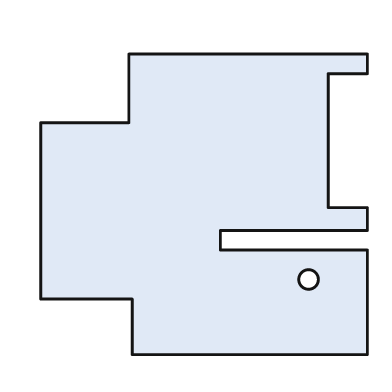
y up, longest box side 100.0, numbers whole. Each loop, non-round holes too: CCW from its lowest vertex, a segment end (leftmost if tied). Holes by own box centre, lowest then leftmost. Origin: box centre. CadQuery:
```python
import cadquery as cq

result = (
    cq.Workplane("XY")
    .moveTo(-22.0, -46.0)
    .lineTo(50.0, -46.0)
    .lineTo(50.0, -14.0)
    .lineTo(5.0, -14.0)
    .lineTo(5.0, -8.0)
    .lineTo(50.0, -8.0)
    .lineTo(50.0, -1.0)
    .lineTo(38.0, -1.0)
    .lineTo(38.0, 40.0)
    .lineTo(50.0, 40.0)
    .lineTo(50.0, 46.0)
    .lineTo(-23.0, 46.0)
    .lineTo(-23.0, 25.0)
    .lineTo(-50.0, 25.0)
    .lineTo(-50.0, -29.0)
    .lineTo(-22.0, -29.0)
    .close()
    .moveTo(32.0, -23.0)
    .circle(3.0)
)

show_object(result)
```